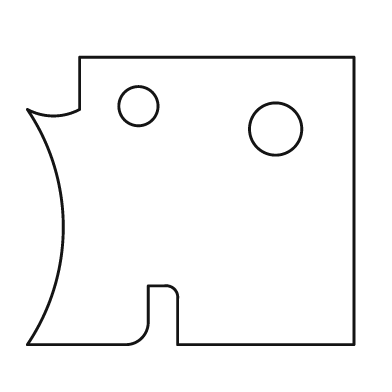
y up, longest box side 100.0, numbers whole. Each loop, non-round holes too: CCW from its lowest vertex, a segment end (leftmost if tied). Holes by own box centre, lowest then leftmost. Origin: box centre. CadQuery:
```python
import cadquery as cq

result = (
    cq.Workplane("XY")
    .moveTo(-50.0, -44.0)
    .lineTo(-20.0, -44.0)
    .threePointArc((-15.0, -42.0), (-13.0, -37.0))
    .lineTo(-13.0, -26.0)
    .lineTo(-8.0, -26.0)
    .threePointArc((-5.0, -27.0), (-4.0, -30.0))
    .lineTo(-4.0, -44.0)
    .lineTo(50.0, -44.0)
    .lineTo(50.0, 44.0)
    .lineTo(-34.0, 44.0)
    .lineTo(-34.0, 28.0)
    .threePointArc((-42.0, 26.0), (-50.0, 28.0))
    .threePointArc((-39.0, -8.0), (-50.0, -44.0))
    .close()
    .moveTo(26.0, 22.0)
    .circle(8.0)
    .moveTo(-16.0, 29.0)
    .circle(6.0)
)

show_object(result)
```